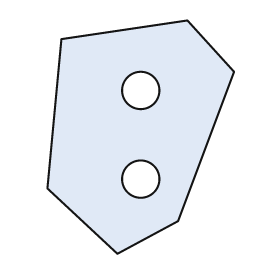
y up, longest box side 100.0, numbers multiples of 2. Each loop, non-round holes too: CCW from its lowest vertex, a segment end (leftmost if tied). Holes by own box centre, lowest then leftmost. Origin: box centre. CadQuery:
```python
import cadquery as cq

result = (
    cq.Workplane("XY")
    .moveTo(-10.0, -50.0)
    .lineTo(16.0, -36.0)
    .lineTo(40.0, 28.0)
    .lineTo(20.0, 50.0)
    .lineTo(-34.0, 42.0)
    .lineTo(-40.0, -22.0)
    .close()
    .moveTo(0.0, -18.0)
    .circle(8.0)
    .moveTo(0.0, 20.0)
    .circle(8.0)
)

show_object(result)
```